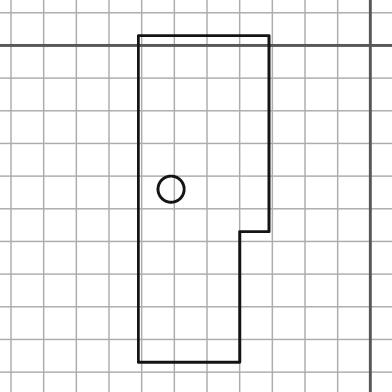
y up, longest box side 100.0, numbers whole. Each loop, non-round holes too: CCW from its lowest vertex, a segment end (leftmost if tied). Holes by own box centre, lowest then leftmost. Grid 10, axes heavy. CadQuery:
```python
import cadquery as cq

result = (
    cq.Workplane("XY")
    .moveTo(-71.0, -97.0)
    .lineTo(-40.0, -97.0)
    .lineTo(-40.0, -57.0)
    .lineTo(-31.0, -57.0)
    .lineTo(-31.0, 3.0)
    .lineTo(-71.0, 3.0)
    .close()
    .moveTo(-61.0, -44.0)
    .circle(4.0)
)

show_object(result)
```